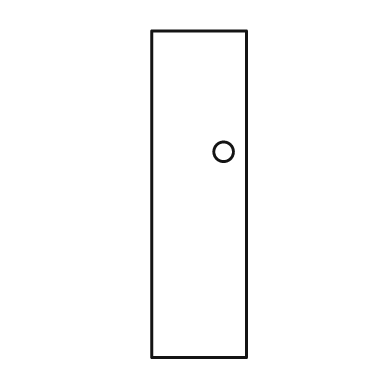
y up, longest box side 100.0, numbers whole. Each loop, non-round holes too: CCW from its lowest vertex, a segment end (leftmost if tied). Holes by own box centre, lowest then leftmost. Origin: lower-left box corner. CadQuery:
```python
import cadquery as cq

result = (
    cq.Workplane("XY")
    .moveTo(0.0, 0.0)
    .lineTo(29.0, 0.0)
    .lineTo(29.0, 100.0)
    .lineTo(0.0, 100.0)
    .close()
    .moveTo(22.0, 63.0)
    .circle(3.0)
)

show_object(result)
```